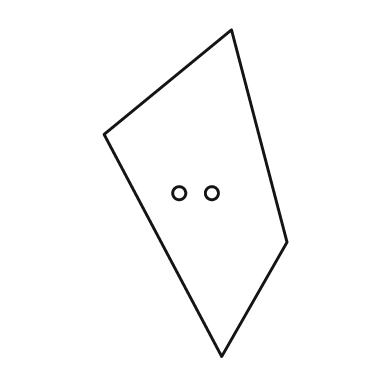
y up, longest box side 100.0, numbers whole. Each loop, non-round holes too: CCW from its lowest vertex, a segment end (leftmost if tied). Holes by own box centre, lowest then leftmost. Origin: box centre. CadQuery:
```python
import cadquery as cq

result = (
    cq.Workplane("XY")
    .moveTo(8.0, -50.0)
    .lineTo(28.0, -15.0)
    .lineTo(11.0, 50.0)
    .lineTo(-28.0, 18.0)
    .close()
    .moveTo(-5.0, 0.0)
    .circle(2.0)
    .moveTo(5.0, 0.0)
    .circle(2.0)
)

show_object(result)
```